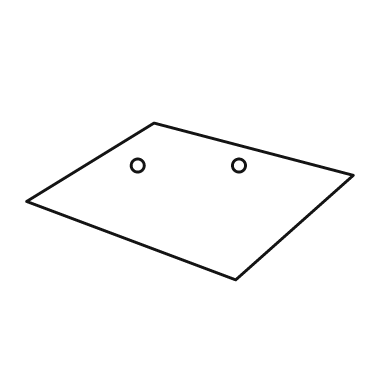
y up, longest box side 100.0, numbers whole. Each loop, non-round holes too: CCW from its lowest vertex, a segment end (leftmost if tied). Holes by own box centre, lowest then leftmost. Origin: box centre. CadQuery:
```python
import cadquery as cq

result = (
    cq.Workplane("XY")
    .moveTo(14.0, -24.0)
    .lineTo(50.0, 8.0)
    .lineTo(-11.0, 24.0)
    .lineTo(-50.0, 0.0)
    .close()
    .moveTo(-16.0, 11.0)
    .circle(2.0)
    .moveTo(15.0, 11.0)
    .circle(2.0)
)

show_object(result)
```